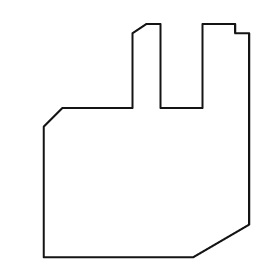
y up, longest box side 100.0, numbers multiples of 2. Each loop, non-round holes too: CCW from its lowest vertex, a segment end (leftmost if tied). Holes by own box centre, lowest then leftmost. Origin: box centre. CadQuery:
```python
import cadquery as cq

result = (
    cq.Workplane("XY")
    .moveTo(-44.0, -50.0)
    .lineTo(20.0, -50.0)
    .lineTo(44.0, -36.0)
    .lineTo(44.0, 46.0)
    .lineTo(38.0, 46.0)
    .lineTo(38.0, 50.0)
    .lineTo(24.0, 50.0)
    .lineTo(24.0, 14.0)
    .lineTo(6.0, 14.0)
    .lineTo(6.0, 50.0)
    .lineTo(0.0, 50.0)
    .lineTo(-6.0, 46.0)
    .lineTo(-6.0, 14.0)
    .lineTo(-36.0, 14.0)
    .lineTo(-44.0, 6.0)
    .close()
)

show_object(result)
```